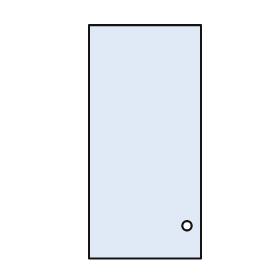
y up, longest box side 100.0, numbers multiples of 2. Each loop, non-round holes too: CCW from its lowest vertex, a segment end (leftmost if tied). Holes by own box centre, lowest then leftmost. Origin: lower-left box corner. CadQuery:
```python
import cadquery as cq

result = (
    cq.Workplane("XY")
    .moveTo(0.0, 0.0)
    .lineTo(48.0, 0.0)
    .lineTo(48.0, 100.0)
    .lineTo(0.0, 100.0)
    .close()
    .moveTo(42.0, 14.0)
    .circle(2.0)
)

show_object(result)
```